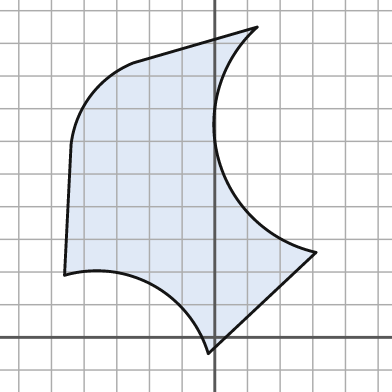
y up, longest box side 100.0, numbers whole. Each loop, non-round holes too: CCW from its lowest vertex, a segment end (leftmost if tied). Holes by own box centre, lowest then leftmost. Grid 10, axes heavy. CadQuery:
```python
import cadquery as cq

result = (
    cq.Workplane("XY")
    .moveTo(-2.0, -5.0)
    .lineTo(31.0, 26.0)
    .threePointArc((1.0, 55.0), (13.0, 95.0))
    .lineTo(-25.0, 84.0)
    .threePointArc((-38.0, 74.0), (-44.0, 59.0))
    .lineTo(-46.0, 19.0)
    .threePointArc((-19.0, 16.0), (-2.0, -5.0))
    .close()
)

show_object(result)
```